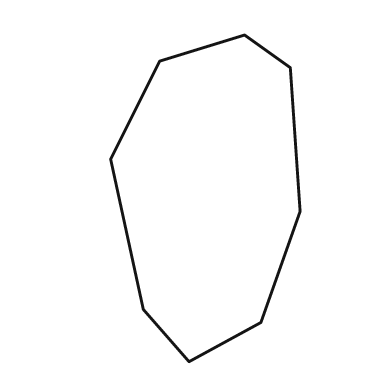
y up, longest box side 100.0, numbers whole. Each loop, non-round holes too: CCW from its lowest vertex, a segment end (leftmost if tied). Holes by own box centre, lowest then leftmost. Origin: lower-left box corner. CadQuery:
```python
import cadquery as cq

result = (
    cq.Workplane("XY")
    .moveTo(24.0, 0.0)
    .lineTo(46.0, 12.0)
    .lineTo(58.0, 46.0)
    .lineTo(55.0, 90.0)
    .lineTo(41.0, 100.0)
    .lineTo(15.0, 92.0)
    .lineTo(0.0, 62.0)
    .lineTo(10.0, 16.0)
    .close()
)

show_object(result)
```